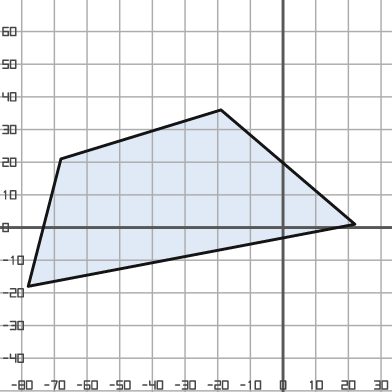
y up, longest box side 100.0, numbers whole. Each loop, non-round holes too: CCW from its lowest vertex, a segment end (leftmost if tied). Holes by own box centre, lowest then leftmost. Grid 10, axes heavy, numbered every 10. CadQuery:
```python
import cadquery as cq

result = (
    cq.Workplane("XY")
    .moveTo(-78.0, -18.0)
    .lineTo(22.0, 1.0)
    .lineTo(-19.0, 36.0)
    .lineTo(-68.0, 21.0)
    .close()
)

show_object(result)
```